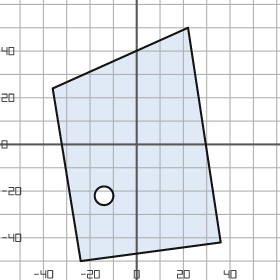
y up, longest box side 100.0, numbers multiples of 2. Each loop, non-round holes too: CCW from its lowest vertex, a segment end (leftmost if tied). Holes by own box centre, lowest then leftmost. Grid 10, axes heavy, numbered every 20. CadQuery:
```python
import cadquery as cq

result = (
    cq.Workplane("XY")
    .moveTo(-24.0, -50.0)
    .lineTo(36.0, -42.0)
    .lineTo(22.0, 50.0)
    .lineTo(-36.0, 24.0)
    .close()
    .moveTo(-14.0, -22.0)
    .circle(4.0)
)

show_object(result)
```